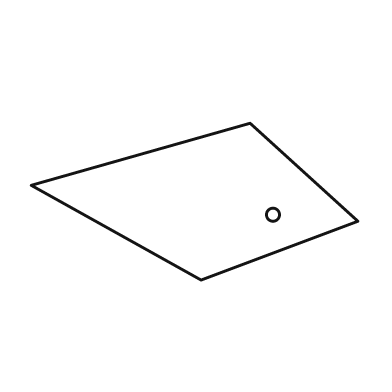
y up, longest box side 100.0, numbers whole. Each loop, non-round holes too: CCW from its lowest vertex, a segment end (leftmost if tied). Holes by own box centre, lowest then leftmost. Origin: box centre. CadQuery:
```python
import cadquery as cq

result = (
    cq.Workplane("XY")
    .moveTo(2.0, -24.0)
    .lineTo(50.0, -6.0)
    .lineTo(17.0, 24.0)
    .lineTo(-50.0, 5.0)
    .close()
    .moveTo(24.0, -4.0)
    .circle(2.0)
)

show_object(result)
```